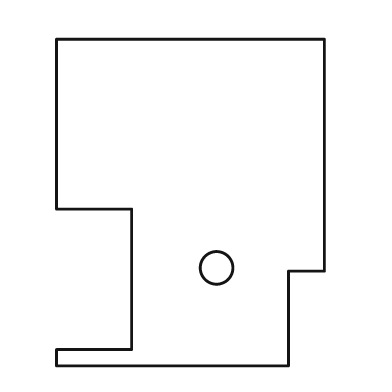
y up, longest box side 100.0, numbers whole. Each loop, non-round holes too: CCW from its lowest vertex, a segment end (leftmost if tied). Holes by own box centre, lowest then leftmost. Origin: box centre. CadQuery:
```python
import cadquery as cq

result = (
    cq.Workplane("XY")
    .moveTo(-41.0, -50.0)
    .lineTo(30.0, -50.0)
    .lineTo(30.0, -21.0)
    .lineTo(41.0, -21.0)
    .lineTo(41.0, 50.0)
    .lineTo(-41.0, 50.0)
    .lineTo(-41.0, -2.0)
    .lineTo(-18.0, -2.0)
    .lineTo(-18.0, -45.0)
    .lineTo(-41.0, -45.0)
    .close()
    .moveTo(8.0, -20.0)
    .circle(5.0)
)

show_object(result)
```